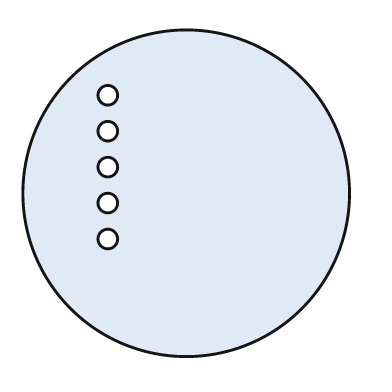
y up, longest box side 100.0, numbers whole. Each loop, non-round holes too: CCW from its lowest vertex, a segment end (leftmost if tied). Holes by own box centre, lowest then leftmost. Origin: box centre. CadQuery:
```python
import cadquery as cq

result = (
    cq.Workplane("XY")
    .moveTo(0.0, 0.0)
    .circle(50.0)
    .moveTo(-24.0, -14.0)
    .circle(3.0)
    .moveTo(-24.0, -3.0)
    .circle(3.0)
    .moveTo(-24.0, 8.0)
    .circle(3.0)
    .moveTo(-24.0, 19.0)
    .circle(3.0)
    .moveTo(-24.0, 30.0)
    .circle(3.0)
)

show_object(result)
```